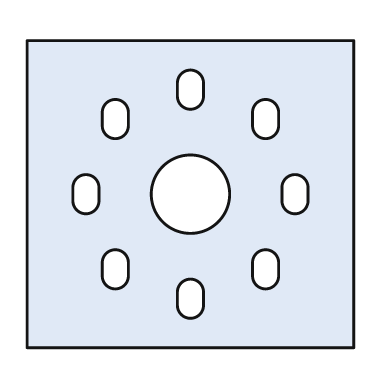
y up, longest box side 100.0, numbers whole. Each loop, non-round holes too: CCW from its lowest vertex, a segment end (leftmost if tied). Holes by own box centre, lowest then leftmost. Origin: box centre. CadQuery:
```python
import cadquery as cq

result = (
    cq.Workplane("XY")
    .moveTo(-50.0, -47.0)
    .lineTo(50.0, -47.0)
    .lineTo(50.0, 47.0)
    .lineTo(-50.0, 47.0)
    .close()
    .moveTo(-4.0, -34.0)
    .threePointArc((0.0, -38.0), (4.0, -34.0))
    .lineTo(4.0, -30.0)
    .threePointArc((0.0, -26.0), (-4.0, -30.0))
    .close()
    .moveTo(-27.0, -25.0)
    .threePointArc((-23.0, -29.0), (-19.0, -25.0))
    .lineTo(-19.0, -21.0)
    .threePointArc((-23.0, -17.0), (-27.0, -21.0))
    .close()
    .moveTo(19.0, -25.0)
    .threePointArc((23.0, -29.0), (27.0, -25.0))
    .lineTo(27.0, -21.0)
    .threePointArc((23.0, -17.0), (19.0, -21.0))
    .close()
    .moveTo(-36.0, -2.0)
    .threePointArc((-32.0, -6.0), (-28.0, -2.0))
    .lineTo(-28.0, 2.0)
    .threePointArc((-32.0, 6.0), (-36.0, 2.0))
    .close()
    .moveTo(0.0, 0.0)
    .circle(12.0)
    .moveTo(28.0, -2.0)
    .threePointArc((32.0, -6.0), (36.0, -2.0))
    .lineTo(36.0, 2.0)
    .threePointArc((32.0, 6.0), (28.0, 2.0))
    .close()
    .moveTo(-27.0, 21.0)
    .threePointArc((-23.0, 17.0), (-19.0, 21.0))
    .lineTo(-19.0, 25.0)
    .threePointArc((-23.0, 29.0), (-27.0, 25.0))
    .close()
    .moveTo(19.0, 21.0)
    .threePointArc((23.0, 17.0), (27.0, 21.0))
    .lineTo(27.0, 25.0)
    .threePointArc((23.0, 29.0), (19.0, 25.0))
    .close()
    .moveTo(-4.0, 30.0)
    .threePointArc((0.0, 26.0), (4.0, 30.0))
    .lineTo(4.0, 34.0)
    .threePointArc((0.0, 38.0), (-4.0, 34.0))
    .close()
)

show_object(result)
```